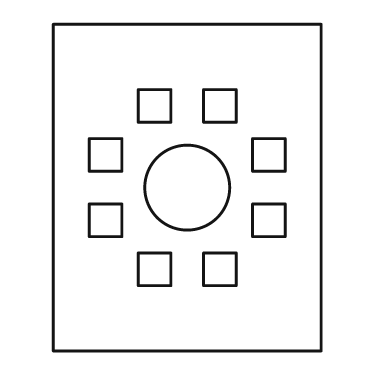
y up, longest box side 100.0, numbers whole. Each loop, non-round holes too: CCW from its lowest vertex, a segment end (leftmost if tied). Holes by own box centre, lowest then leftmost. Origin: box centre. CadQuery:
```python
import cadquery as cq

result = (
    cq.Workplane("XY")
    .moveTo(-41.0, -50.0)
    .lineTo(41.0, -50.0)
    .lineTo(41.0, 50.0)
    .lineTo(-41.0, 50.0)
    .close()
    .moveTo(-15.0, -30.0)
    .lineTo(-5.0, -30.0)
    .lineTo(-5.0, -20.0)
    .lineTo(-15.0, -20.0)
    .close()
    .moveTo(5.0, -30.0)
    .lineTo(15.0, -30.0)
    .lineTo(15.0, -20.0)
    .lineTo(5.0, -20.0)
    .close()
    .moveTo(-30.0, -15.0)
    .lineTo(-20.0, -15.0)
    .lineTo(-20.0, -5.0)
    .lineTo(-30.0, -5.0)
    .close()
    .moveTo(20.0, -15.0)
    .lineTo(30.0, -15.0)
    .lineTo(30.0, -5.0)
    .lineTo(20.0, -5.0)
    .close()
    .moveTo(0.0, 0.0)
    .circle(13.0)
    .moveTo(-30.0, 5.0)
    .lineTo(-20.0, 5.0)
    .lineTo(-20.0, 15.0)
    .lineTo(-30.0, 15.0)
    .close()
    .moveTo(20.0, 5.0)
    .lineTo(30.0, 5.0)
    .lineTo(30.0, 15.0)
    .lineTo(20.0, 15.0)
    .close()
    .moveTo(-15.0, 20.0)
    .lineTo(-5.0, 20.0)
    .lineTo(-5.0, 30.0)
    .lineTo(-15.0, 30.0)
    .close()
    .moveTo(5.0, 20.0)
    .lineTo(15.0, 20.0)
    .lineTo(15.0, 30.0)
    .lineTo(5.0, 30.0)
    .close()
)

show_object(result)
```